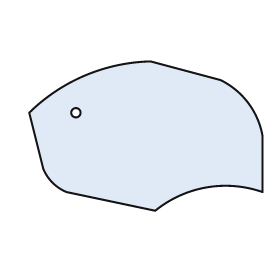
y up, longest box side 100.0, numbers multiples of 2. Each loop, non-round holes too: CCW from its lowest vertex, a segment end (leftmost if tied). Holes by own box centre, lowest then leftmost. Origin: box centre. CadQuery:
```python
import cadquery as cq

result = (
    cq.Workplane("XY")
    .moveTo(4.0, -32.0)
    .threePointArc((26.0, -22.0), (50.0, -24.0))
    .lineTo(50.0, 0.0)
    .threePointArc((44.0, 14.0), (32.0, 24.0))
    .lineTo(2.0, 32.0)
    .threePointArc((-26.0, 26.0), (-50.0, 10.0))
    .lineTo(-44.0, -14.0)
    .threePointArc((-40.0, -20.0), (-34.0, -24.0))
    .close()
    .moveTo(-30.0, 10.0)
    .circle(2.0)
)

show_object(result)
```